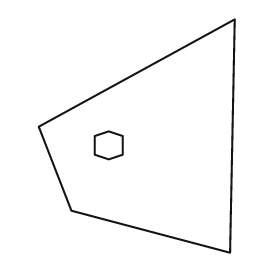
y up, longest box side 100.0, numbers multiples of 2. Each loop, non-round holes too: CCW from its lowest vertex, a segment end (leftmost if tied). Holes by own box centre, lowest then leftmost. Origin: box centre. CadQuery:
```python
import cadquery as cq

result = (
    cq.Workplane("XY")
    .moveTo(40.0, -50.0)
    .lineTo(42.0, 50.0)
    .lineTo(-42.0, 4.0)
    .lineTo(-28.0, -32.0)
    .close()
    .moveTo(-12.0, -10.0)
    .lineTo(-6.0, -8.0)
    .lineTo(-6.0, 0.0)
    .lineTo(-12.0, 2.0)
    .lineTo(-18.0, 0.0)
    .lineTo(-18.0, -8.0)
    .close()
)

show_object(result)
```